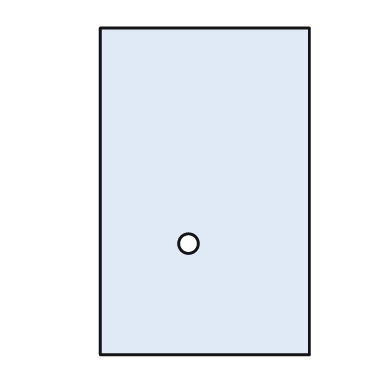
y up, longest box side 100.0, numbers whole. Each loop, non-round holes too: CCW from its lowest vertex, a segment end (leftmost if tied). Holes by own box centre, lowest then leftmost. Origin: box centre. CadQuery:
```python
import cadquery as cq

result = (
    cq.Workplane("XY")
    .moveTo(-32.0, -50.0)
    .lineTo(32.0, -50.0)
    .lineTo(32.0, 50.0)
    .lineTo(-32.0, 50.0)
    .close()
    .moveTo(-5.0, -16.0)
    .circle(3.0)
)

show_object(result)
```